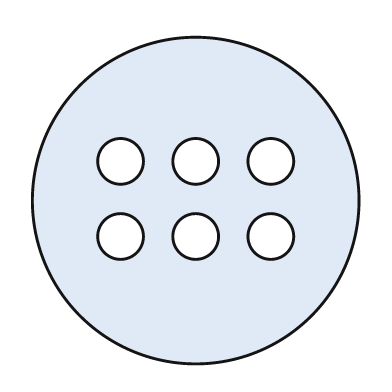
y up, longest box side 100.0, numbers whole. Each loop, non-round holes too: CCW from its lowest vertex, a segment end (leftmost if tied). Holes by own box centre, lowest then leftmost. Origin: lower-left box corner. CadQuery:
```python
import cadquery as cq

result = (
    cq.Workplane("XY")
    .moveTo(50.0, 50.0)
    .circle(50.0)
    .moveTo(27.0, 39.0)
    .circle(7.0)
    .moveTo(50.0, 39.0)
    .circle(7.0)
    .moveTo(73.0, 39.0)
    .circle(7.0)
    .moveTo(27.0, 62.0)
    .circle(7.0)
    .moveTo(50.0, 62.0)
    .circle(7.0)
    .moveTo(73.0, 62.0)
    .circle(7.0)
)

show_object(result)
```